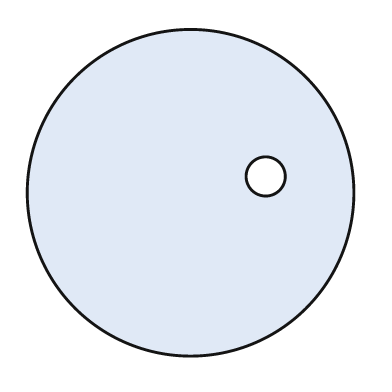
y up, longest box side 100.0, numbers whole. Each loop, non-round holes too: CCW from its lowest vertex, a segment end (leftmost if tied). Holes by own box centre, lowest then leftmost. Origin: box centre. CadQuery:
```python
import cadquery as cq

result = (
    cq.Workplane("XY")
    .moveTo(0.0, 0.0)
    .circle(50.0)
    .moveTo(23.0, 5.0)
    .circle(6.0)
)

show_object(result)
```